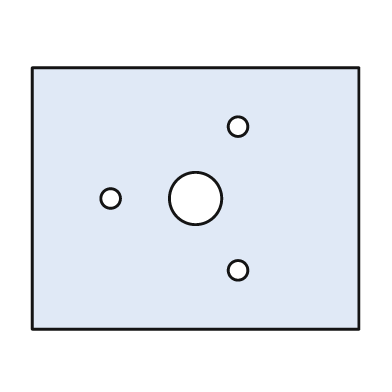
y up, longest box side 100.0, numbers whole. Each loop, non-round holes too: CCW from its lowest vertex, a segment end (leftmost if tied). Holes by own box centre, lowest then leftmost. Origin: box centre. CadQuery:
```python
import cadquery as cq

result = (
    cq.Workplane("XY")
    .moveTo(-50.0, -40.0)
    .lineTo(50.0, -40.0)
    .lineTo(50.0, 40.0)
    .lineTo(-50.0, 40.0)
    .close()
    .moveTo(13.0, -22.0)
    .circle(3.0)
    .moveTo(-26.0, 0.0)
    .circle(3.0)
    .moveTo(0.0, 0.0)
    .circle(8.0)
    .moveTo(13.0, 22.0)
    .circle(3.0)
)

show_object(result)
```